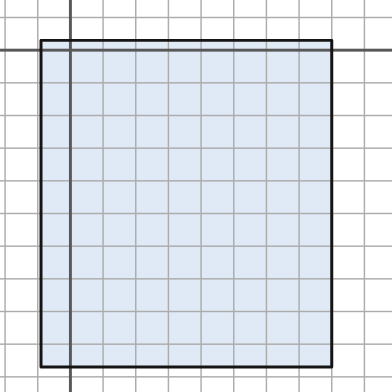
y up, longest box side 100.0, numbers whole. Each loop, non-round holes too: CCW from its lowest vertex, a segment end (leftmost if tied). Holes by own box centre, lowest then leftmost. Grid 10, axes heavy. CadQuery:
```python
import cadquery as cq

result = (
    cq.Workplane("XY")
    .moveTo(-9.0, -97.0)
    .lineTo(80.0, -97.0)
    .lineTo(80.0, 3.0)
    .lineTo(-9.0, 3.0)
    .close()
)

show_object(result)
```